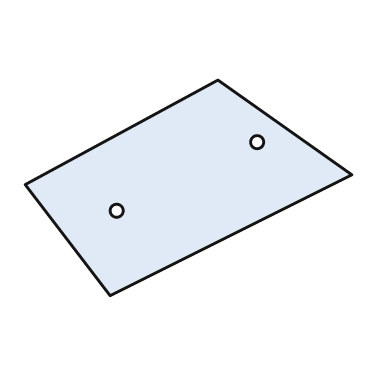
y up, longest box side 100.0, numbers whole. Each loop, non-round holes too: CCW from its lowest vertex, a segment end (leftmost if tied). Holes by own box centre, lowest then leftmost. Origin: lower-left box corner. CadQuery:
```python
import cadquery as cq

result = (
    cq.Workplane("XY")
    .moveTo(26.0, 0.0)
    .lineTo(100.0, 37.0)
    .lineTo(59.0, 66.0)
    .lineTo(0.0, 34.0)
    .close()
    .moveTo(28.0, 26.0)
    .circle(2.0)
    .moveTo(71.0, 47.0)
    .circle(2.0)
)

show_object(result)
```